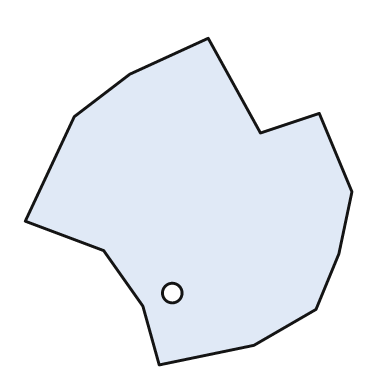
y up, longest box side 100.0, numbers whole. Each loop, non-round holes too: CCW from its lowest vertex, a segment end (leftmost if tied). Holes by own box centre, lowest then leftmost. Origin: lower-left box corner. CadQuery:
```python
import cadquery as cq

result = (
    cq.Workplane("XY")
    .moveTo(41.0, 0.0)
    .lineTo(70.0, 6.0)
    .lineTo(89.0, 17.0)
    .lineTo(96.0, 34.0)
    .lineTo(100.0, 53.0)
    .lineTo(90.0, 77.0)
    .lineTo(72.0, 71.0)
    .lineTo(56.0, 100.0)
    .lineTo(32.0, 89.0)
    .lineTo(15.0, 76.0)
    .lineTo(0.0, 44.0)
    .lineTo(24.0, 35.0)
    .lineTo(36.0, 18.0)
    .close()
    .moveTo(45.0, 22.0)
    .circle(3.0)
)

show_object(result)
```